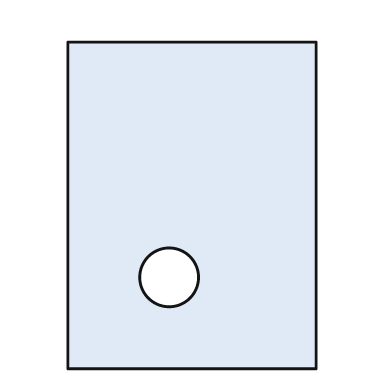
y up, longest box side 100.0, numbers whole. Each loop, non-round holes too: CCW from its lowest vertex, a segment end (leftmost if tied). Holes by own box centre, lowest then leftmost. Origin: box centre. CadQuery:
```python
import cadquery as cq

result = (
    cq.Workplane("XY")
    .moveTo(-38.0, -50.0)
    .lineTo(38.0, -50.0)
    .lineTo(38.0, 50.0)
    .lineTo(-38.0, 50.0)
    .close()
    .moveTo(-7.0, -22.0)
    .circle(9.0)
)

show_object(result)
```